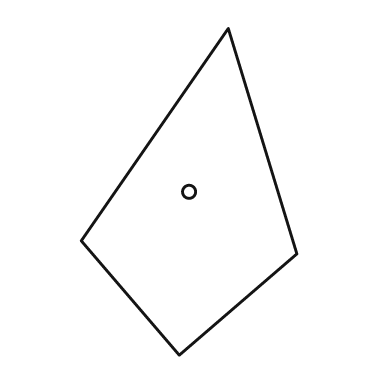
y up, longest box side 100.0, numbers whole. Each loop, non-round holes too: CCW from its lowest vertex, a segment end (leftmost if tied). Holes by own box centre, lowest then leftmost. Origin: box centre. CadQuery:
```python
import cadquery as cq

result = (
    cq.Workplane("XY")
    .moveTo(-3.0, -50.0)
    .lineTo(33.0, -19.0)
    .lineTo(12.0, 50.0)
    .lineTo(-33.0, -15.0)
    .close()
    .moveTo(0.0, 0.0)
    .circle(2.0)
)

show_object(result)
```